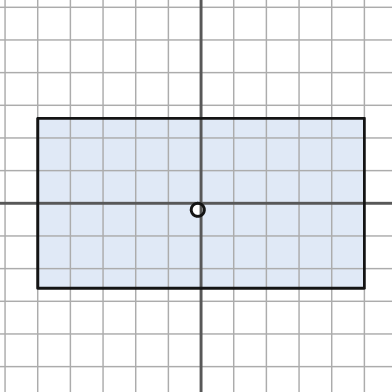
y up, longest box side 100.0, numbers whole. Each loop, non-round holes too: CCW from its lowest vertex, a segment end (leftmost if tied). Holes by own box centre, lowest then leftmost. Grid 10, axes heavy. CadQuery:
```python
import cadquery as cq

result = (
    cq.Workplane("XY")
    .moveTo(-50.0, -26.0)
    .lineTo(50.0, -26.0)
    .lineTo(50.0, 26.0)
    .lineTo(-50.0, 26.0)
    .close()
    .moveTo(-1.0, -2.0)
    .circle(2.0)
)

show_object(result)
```